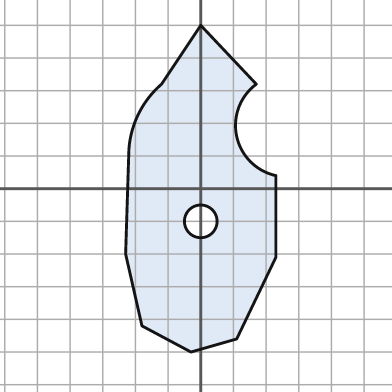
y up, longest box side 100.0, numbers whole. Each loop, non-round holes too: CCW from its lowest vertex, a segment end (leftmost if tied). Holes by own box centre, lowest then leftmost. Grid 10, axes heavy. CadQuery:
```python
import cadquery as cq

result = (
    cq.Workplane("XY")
    .moveTo(-3.0, -50.0)
    .lineTo(11.0, -46.0)
    .lineTo(23.0, -21.0)
    .lineTo(23.0, 4.0)
    .threePointArc((11.0, 16.0), (17.0, 32.0))
    .lineTo(0.0, 50.0)
    .lineTo(-12.0, 32.0)
    .threePointArc((-19.0, 23.0), (-22.0, 12.0))
    .lineTo(-23.0, -20.0)
    .lineTo(-18.0, -42.0)
    .close()
    .moveTo(0.0, -10.0)
    .circle(5.0)
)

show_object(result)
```